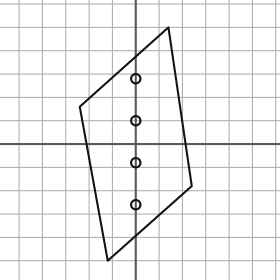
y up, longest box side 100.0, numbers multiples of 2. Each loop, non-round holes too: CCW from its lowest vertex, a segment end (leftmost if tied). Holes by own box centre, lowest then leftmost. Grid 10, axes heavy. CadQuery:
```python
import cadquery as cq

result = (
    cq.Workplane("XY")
    .moveTo(-12.0, -50.0)
    .lineTo(24.0, -18.0)
    .lineTo(14.0, 50.0)
    .lineTo(-24.0, 16.0)
    .close()
    .moveTo(0.0, -26.0)
    .circle(2.0)
    .moveTo(0.0, -8.0)
    .circle(2.0)
    .moveTo(0.0, 10.0)
    .circle(2.0)
    .moveTo(0.0, 28.0)
    .circle(2.0)
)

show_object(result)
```